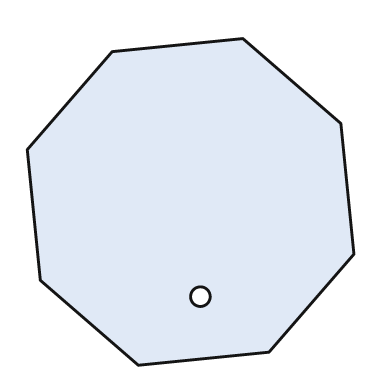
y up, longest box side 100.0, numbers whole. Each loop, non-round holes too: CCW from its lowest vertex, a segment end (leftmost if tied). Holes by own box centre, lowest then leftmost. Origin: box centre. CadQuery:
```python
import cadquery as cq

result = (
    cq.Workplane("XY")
    .moveTo(-16.0, -50.0)
    .lineTo(24.0, -46.0)
    .lineTo(50.0, -16.0)
    .lineTo(46.0, 24.0)
    .lineTo(16.0, 50.0)
    .lineTo(-24.0, 46.0)
    .lineTo(-50.0, 16.0)
    .lineTo(-46.0, -24.0)
    .close()
    .moveTo(3.0, -29.0)
    .circle(3.0)
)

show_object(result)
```